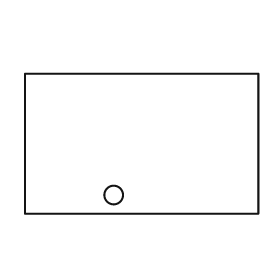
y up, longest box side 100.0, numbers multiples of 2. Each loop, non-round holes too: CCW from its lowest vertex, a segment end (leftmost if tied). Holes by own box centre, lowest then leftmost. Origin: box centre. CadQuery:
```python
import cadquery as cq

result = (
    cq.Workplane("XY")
    .moveTo(-50.0, -30.0)
    .lineTo(50.0, -30.0)
    .lineTo(50.0, 30.0)
    .lineTo(-50.0, 30.0)
    .close()
    .moveTo(-12.0, -22.0)
    .circle(4.0)
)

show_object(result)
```